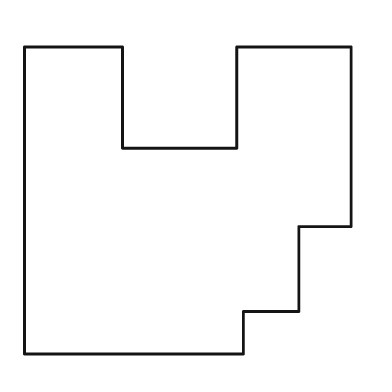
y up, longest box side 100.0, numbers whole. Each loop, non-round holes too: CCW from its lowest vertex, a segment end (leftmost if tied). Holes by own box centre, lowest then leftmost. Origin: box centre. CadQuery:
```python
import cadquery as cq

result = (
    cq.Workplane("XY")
    .moveTo(-50.0, -47.0)
    .lineTo(17.0, -47.0)
    .lineTo(17.0, -34.0)
    .lineTo(34.0, -34.0)
    .lineTo(34.0, -8.0)
    .lineTo(50.0, -8.0)
    .lineTo(50.0, 47.0)
    .lineTo(15.0, 47.0)
    .lineTo(15.0, 16.0)
    .lineTo(-20.0, 16.0)
    .lineTo(-20.0, 47.0)
    .lineTo(-50.0, 47.0)
    .close()
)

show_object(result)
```